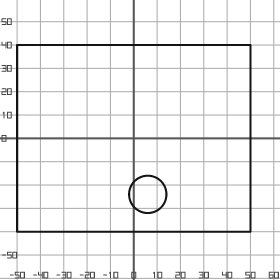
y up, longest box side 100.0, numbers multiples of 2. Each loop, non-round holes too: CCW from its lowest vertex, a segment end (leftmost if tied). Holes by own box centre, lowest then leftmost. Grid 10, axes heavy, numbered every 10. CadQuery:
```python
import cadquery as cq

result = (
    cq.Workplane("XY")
    .moveTo(-50.0, -40.0)
    .lineTo(50.0, -40.0)
    .lineTo(50.0, 40.0)
    .lineTo(-50.0, 40.0)
    .close()
    .moveTo(6.0, -24.0)
    .circle(8.0)
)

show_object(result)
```